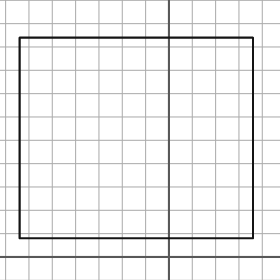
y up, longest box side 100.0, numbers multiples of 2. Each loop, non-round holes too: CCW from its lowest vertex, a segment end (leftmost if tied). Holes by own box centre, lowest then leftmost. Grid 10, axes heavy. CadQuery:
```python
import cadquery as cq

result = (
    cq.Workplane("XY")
    .moveTo(-64.0, 8.0)
    .lineTo(36.0, 8.0)
    .lineTo(36.0, 94.0)
    .lineTo(-64.0, 94.0)
    .close()
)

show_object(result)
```